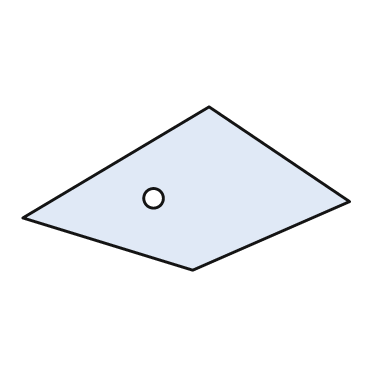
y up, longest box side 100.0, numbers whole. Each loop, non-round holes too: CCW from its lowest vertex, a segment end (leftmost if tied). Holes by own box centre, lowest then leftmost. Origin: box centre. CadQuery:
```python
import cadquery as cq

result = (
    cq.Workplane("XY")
    .moveTo(2.0, -25.0)
    .lineTo(50.0, -4.0)
    .lineTo(7.0, 25.0)
    .lineTo(-50.0, -9.0)
    .close()
    .moveTo(-10.0, -3.0)
    .circle(3.0)
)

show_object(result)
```